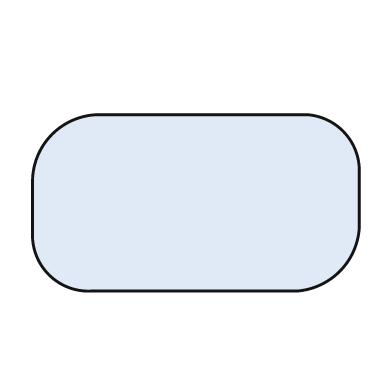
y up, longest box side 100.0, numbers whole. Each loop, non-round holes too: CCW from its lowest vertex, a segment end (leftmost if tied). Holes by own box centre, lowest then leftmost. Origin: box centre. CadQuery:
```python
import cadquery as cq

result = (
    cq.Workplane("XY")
    .moveTo(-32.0, -27.0)
    .lineTo(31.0, -27.0)
    .threePointArc((44.0, -21.0), (50.0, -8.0))
    .lineTo(50.0, 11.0)
    .threePointArc((45.0, 22.0), (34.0, 27.0))
    .lineTo(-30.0, 27.0)
    .threePointArc((-44.0, 21.0), (-50.0, 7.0))
    .lineTo(-50.0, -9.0)
    .threePointArc((-45.0, -22.0), (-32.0, -27.0))
    .close()
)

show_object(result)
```